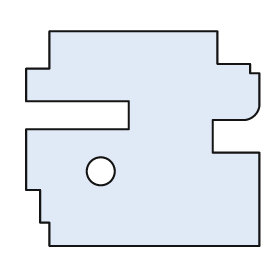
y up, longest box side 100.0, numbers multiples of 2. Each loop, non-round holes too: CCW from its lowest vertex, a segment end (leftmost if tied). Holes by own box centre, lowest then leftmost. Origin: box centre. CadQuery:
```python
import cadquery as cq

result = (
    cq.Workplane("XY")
    .moveTo(-40.0, -46.0)
    .lineTo(50.0, -46.0)
    .lineTo(50.0, -6.0)
    .lineTo(30.0, -6.0)
    .lineTo(30.0, 8.0)
    .lineTo(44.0, 8.0)
    .threePointArc((48.0, 10.0), (50.0, 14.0))
    .lineTo(50.0, 28.0)
    .lineTo(46.0, 28.0)
    .lineTo(46.0, 32.0)
    .lineTo(32.0, 32.0)
    .lineTo(32.0, 46.0)
    .lineTo(-40.0, 46.0)
    .lineTo(-40.0, 30.0)
    .lineTo(-50.0, 30.0)
    .lineTo(-50.0, 16.0)
    .lineTo(-6.0, 16.0)
    .lineTo(-6.0, 4.0)
    .lineTo(-50.0, 4.0)
    .lineTo(-50.0, -22.0)
    .lineTo(-44.0, -22.0)
    .lineTo(-44.0, -36.0)
    .lineTo(-40.0, -36.0)
    .close()
    .moveTo(-18.0, -14.0)
    .circle(6.0)
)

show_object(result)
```